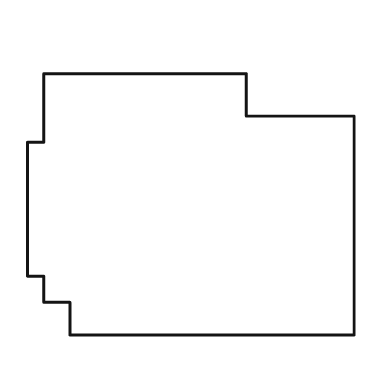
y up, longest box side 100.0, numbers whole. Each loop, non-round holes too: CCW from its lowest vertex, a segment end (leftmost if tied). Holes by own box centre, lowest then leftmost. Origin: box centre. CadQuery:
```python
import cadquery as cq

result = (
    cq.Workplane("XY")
    .moveTo(-37.0, -40.0)
    .lineTo(50.0, -40.0)
    .lineTo(50.0, 27.0)
    .lineTo(17.0, 27.0)
    .lineTo(17.0, 40.0)
    .lineTo(-45.0, 40.0)
    .lineTo(-45.0, 19.0)
    .lineTo(-50.0, 19.0)
    .lineTo(-50.0, -22.0)
    .lineTo(-45.0, -22.0)
    .lineTo(-45.0, -30.0)
    .lineTo(-37.0, -30.0)
    .close()
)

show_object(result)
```